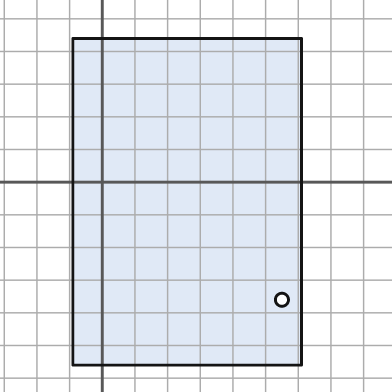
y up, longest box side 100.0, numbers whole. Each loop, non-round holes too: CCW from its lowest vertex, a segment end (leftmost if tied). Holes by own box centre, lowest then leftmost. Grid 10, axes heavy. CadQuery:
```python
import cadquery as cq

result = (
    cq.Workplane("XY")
    .moveTo(-9.0, -56.0)
    .lineTo(61.0, -56.0)
    .lineTo(61.0, 44.0)
    .lineTo(-9.0, 44.0)
    .close()
    .moveTo(55.0, -36.0)
    .circle(2.0)
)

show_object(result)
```